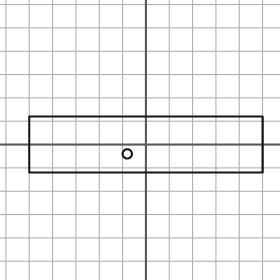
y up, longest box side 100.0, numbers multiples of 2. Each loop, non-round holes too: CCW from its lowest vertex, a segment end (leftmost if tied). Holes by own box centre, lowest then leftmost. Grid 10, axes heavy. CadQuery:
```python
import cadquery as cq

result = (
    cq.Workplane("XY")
    .moveTo(-50.0, -12.0)
    .lineTo(50.0, -12.0)
    .lineTo(50.0, 12.0)
    .lineTo(-50.0, 12.0)
    .close()
    .moveTo(-8.0, -4.0)
    .circle(2.0)
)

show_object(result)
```